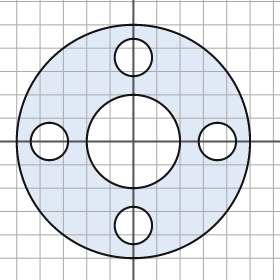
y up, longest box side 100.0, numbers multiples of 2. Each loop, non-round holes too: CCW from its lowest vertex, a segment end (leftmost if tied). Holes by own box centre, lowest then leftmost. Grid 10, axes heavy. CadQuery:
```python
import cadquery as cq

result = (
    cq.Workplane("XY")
    .moveTo(0.0, 0.0)
    .circle(50.0)
    .moveTo(0.0, -36.0)
    .circle(8.0)
    .moveTo(-36.0, 0.0)
    .circle(8.0)
    .moveTo(0.0, 0.0)
    .circle(20.0)
    .moveTo(36.0, 0.0)
    .circle(8.0)
    .moveTo(0.0, 36.0)
    .circle(8.0)
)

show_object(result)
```